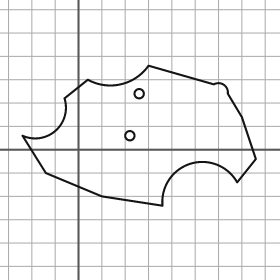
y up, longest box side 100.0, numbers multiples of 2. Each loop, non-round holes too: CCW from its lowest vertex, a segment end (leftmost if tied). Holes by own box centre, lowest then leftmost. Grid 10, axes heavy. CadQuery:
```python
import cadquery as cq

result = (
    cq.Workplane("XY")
    .moveTo(36.0, -24.0)
    .threePointArc((48.0, -6.0), (68.0, -14.0))
    .lineTo(76.0, -4.0)
    .lineTo(70.0, 14.0)
    .lineTo(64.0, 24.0)
    .threePointArc((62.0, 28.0), (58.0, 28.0))
    .lineTo(30.0, 36.0)
    .threePointArc((18.0, 28.0), (4.0, 30.0))
    .lineTo(-6.0, 22.0)
    .threePointArc((-10.0, 8.0), (-24.0, 6.0))
    .lineTo(-14.0, -10.0)
    .lineTo(10.0, -20.0)
    .close()
    .moveTo(22.0, 6.0)
    .circle(2.0)
    .moveTo(26.0, 24.0)
    .circle(2.0)
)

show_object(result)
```